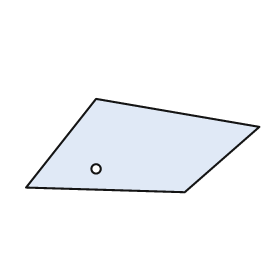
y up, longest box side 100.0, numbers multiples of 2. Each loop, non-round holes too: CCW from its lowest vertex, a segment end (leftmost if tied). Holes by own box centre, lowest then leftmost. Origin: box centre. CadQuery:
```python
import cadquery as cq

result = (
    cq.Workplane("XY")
    .moveTo(18.0, -20.0)
    .lineTo(50.0, 8.0)
    .lineTo(-20.0, 20.0)
    .lineTo(-50.0, -18.0)
    .close()
    .moveTo(-20.0, -10.0)
    .circle(2.0)
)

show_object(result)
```